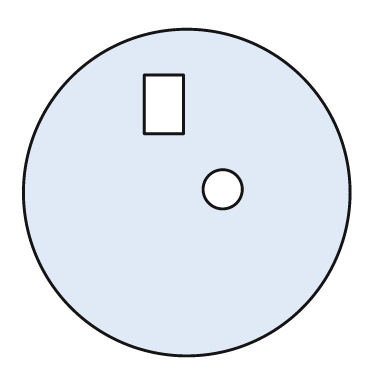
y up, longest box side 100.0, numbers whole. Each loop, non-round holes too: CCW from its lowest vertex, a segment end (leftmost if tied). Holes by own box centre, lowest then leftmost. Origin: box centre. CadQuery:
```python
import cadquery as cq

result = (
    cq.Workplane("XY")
    .moveTo(0.0, 0.0)
    .circle(50.0)
    .moveTo(11.0, 1.0)
    .circle(6.0)
    .moveTo(-13.0, 18.0)
    .lineTo(-1.0, 18.0)
    .lineTo(-1.0, 36.0)
    .lineTo(-13.0, 36.0)
    .close()
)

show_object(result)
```